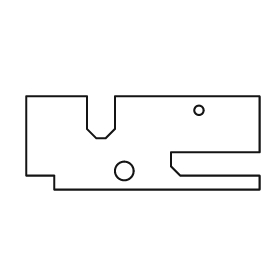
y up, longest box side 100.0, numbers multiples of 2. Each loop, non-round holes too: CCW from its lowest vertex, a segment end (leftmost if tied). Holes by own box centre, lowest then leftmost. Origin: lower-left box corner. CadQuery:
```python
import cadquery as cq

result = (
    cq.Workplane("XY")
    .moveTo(12.0, 0.0)
    .lineTo(100.0, 0.0)
    .lineTo(100.0, 6.0)
    .lineTo(66.0, 6.0)
    .lineTo(62.0, 10.0)
    .lineTo(62.0, 16.0)
    .lineTo(100.0, 16.0)
    .lineTo(100.0, 40.0)
    .lineTo(38.0, 40.0)
    .lineTo(38.0, 26.0)
    .lineTo(34.0, 22.0)
    .lineTo(30.0, 22.0)
    .lineTo(26.0, 26.0)
    .lineTo(26.0, 40.0)
    .lineTo(0.0, 40.0)
    .lineTo(0.0, 6.0)
    .lineTo(12.0, 6.0)
    .close()
    .moveTo(42.0, 8.0)
    .circle(4.0)
    .moveTo(74.0, 34.0)
    .circle(2.0)
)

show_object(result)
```